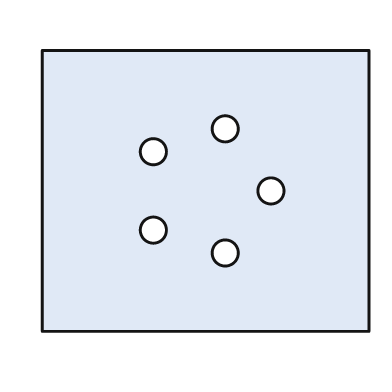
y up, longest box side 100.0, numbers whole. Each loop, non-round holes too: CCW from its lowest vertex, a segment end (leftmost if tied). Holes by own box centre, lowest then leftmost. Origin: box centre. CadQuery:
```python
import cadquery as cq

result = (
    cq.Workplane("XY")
    .moveTo(-50.0, -43.0)
    .lineTo(50.0, -43.0)
    .lineTo(50.0, 43.0)
    .lineTo(-50.0, 43.0)
    .close()
    .moveTo(6.0, -19.0)
    .circle(4.0)
    .moveTo(-16.0, -12.0)
    .circle(4.0)
    .moveTo(20.0, 0.0)
    .circle(4.0)
    .moveTo(-16.0, 12.0)
    .circle(4.0)
    .moveTo(6.0, 19.0)
    .circle(4.0)
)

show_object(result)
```